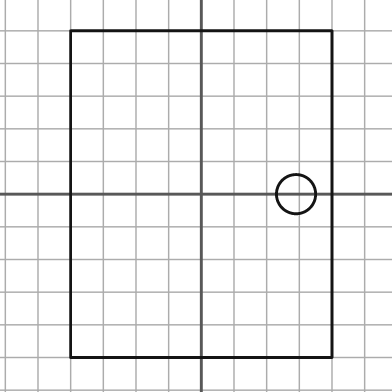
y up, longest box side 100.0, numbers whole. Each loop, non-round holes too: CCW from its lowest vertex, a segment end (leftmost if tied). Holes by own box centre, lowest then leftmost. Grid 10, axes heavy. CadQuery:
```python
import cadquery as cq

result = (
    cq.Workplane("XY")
    .moveTo(-40.0, -50.0)
    .lineTo(40.0, -50.0)
    .lineTo(40.0, 50.0)
    .lineTo(-40.0, 50.0)
    .close()
    .moveTo(29.0, 0.0)
    .circle(6.0)
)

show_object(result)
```